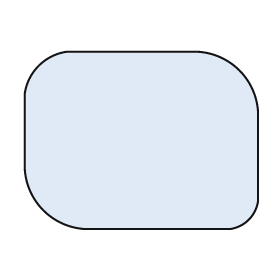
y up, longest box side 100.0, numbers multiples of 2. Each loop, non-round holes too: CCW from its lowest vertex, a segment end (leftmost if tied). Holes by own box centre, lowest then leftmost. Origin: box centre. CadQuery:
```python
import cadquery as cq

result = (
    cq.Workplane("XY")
    .moveTo(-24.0, -38.0)
    .lineTo(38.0, -38.0)
    .threePointArc((46.0, -34.0), (50.0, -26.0))
    .lineTo(50.0, 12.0)
    .threePointArc((42.0, 30.0), (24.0, 38.0))
    .lineTo(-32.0, 38.0)
    .threePointArc((-44.0, 32.0), (-50.0, 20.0))
    .lineTo(-50.0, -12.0)
    .threePointArc((-42.0, -30.0), (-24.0, -38.0))
    .close()
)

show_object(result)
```